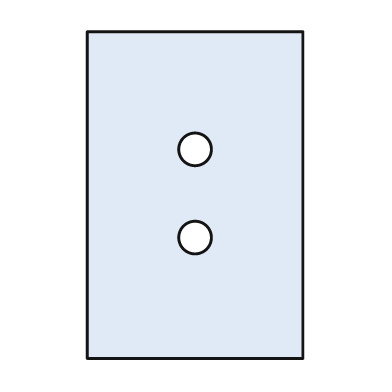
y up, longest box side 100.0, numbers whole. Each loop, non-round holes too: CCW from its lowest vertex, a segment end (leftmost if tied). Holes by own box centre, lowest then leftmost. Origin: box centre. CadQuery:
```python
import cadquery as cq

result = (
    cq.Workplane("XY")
    .moveTo(-33.0, -50.0)
    .lineTo(33.0, -50.0)
    .lineTo(33.0, 50.0)
    .lineTo(-33.0, 50.0)
    .close()
    .moveTo(0.0, -13.0)
    .circle(5.0)
    .moveTo(0.0, 14.0)
    .circle(5.0)
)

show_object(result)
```